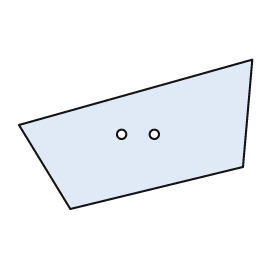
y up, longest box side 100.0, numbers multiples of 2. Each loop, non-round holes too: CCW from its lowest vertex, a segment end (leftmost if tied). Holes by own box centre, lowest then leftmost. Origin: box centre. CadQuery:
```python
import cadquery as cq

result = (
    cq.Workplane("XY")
    .moveTo(-28.0, -32.0)
    .lineTo(46.0, -14.0)
    .lineTo(50.0, 32.0)
    .lineTo(-50.0, 4.0)
    .close()
    .moveTo(-6.0, 0.0)
    .circle(2.0)
    .moveTo(8.0, 0.0)
    .circle(2.0)
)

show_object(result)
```